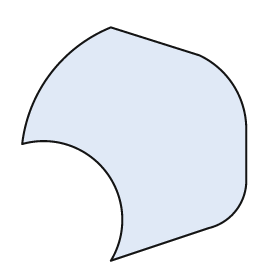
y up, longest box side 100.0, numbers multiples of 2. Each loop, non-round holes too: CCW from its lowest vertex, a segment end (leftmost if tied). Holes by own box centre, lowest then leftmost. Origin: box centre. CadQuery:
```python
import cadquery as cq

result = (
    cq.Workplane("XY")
    .moveTo(-10.0, -50.0)
    .lineTo(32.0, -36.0)
    .threePointArc((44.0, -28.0), (48.0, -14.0))
    .lineTo(48.0, 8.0)
    .threePointArc((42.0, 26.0), (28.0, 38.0))
    .lineTo(-10.0, 50.0)
    .threePointArc((-36.0, 30.0), (-48.0, 0.0))
    .threePointArc((-12.0, -12.0), (-10.0, -50.0))
    .close()
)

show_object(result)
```